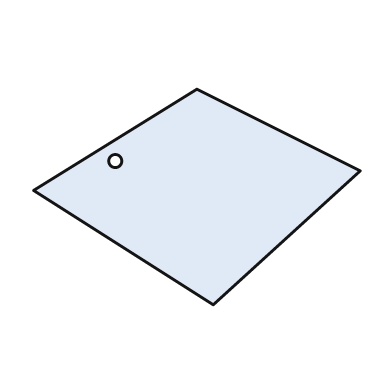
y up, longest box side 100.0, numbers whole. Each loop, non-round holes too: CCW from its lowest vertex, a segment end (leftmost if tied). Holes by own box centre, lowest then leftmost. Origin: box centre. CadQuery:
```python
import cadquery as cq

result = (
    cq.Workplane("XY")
    .moveTo(5.0, -33.0)
    .lineTo(50.0, 8.0)
    .lineTo(0.0, 33.0)
    .lineTo(-50.0, 2.0)
    .close()
    .moveTo(-25.0, 11.0)
    .circle(2.0)
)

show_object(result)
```